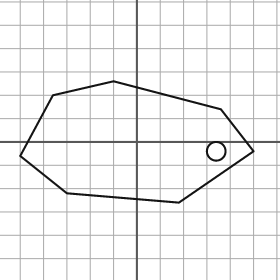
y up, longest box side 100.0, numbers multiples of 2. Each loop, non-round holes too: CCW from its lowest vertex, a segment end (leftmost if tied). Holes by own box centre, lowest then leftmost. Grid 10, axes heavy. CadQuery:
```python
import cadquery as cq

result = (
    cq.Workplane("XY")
    .moveTo(18.0, -26.0)
    .lineTo(50.0, -4.0)
    .lineTo(36.0, 14.0)
    .lineTo(-10.0, 26.0)
    .lineTo(-36.0, 20.0)
    .lineTo(-50.0, -6.0)
    .lineTo(-30.0, -22.0)
    .close()
    .moveTo(34.0, -4.0)
    .circle(4.0)
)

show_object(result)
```